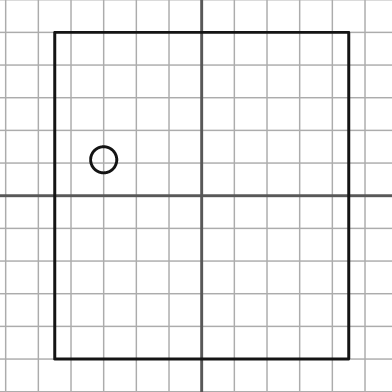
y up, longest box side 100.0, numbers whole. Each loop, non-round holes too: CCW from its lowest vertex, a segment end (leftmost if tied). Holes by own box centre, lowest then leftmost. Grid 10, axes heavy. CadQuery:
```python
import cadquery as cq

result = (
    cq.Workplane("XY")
    .moveTo(-45.0, -50.0)
    .lineTo(45.0, -50.0)
    .lineTo(45.0, 50.0)
    .lineTo(-45.0, 50.0)
    .close()
    .moveTo(-30.0, 11.0)
    .circle(4.0)
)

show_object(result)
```